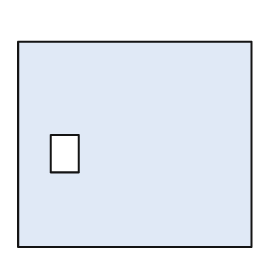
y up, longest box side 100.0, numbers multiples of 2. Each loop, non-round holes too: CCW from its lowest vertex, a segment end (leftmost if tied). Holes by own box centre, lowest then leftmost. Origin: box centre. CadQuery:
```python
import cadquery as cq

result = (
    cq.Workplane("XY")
    .moveTo(-50.0, -44.0)
    .lineTo(50.0, -44.0)
    .lineTo(50.0, 44.0)
    .lineTo(-50.0, 44.0)
    .close()
    .moveTo(-36.0, -12.0)
    .lineTo(-24.0, -12.0)
    .lineTo(-24.0, 4.0)
    .lineTo(-36.0, 4.0)
    .close()
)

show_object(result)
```